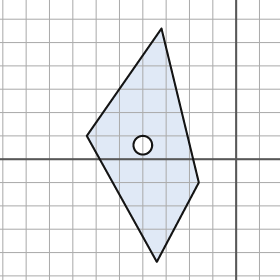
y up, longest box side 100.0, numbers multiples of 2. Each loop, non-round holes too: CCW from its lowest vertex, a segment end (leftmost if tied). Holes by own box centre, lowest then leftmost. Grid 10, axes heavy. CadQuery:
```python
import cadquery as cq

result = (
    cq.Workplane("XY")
    .moveTo(-34.0, -44.0)
    .lineTo(-16.0, -10.0)
    .lineTo(-32.0, 56.0)
    .lineTo(-64.0, 10.0)
    .close()
    .moveTo(-40.0, 6.0)
    .circle(4.0)
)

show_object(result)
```